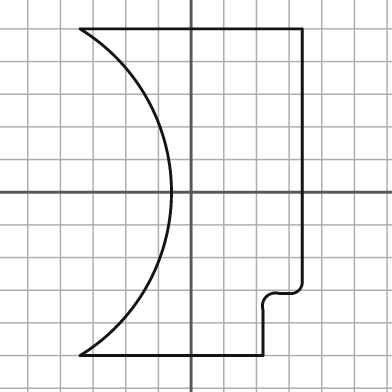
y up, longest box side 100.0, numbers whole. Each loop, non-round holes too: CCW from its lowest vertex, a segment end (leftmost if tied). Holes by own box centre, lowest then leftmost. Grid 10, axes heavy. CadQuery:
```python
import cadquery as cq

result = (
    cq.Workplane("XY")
    .moveTo(-34.0, -50.0)
    .lineTo(22.0, -50.0)
    .lineTo(22.0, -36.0)
    .threePointArc((23.0, -32.0), (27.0, -31.0))
    .lineTo(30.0, -31.0)
    .threePointArc((33.0, -30.0), (34.0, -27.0))
    .lineTo(34.0, 50.0)
    .lineTo(-34.0, 50.0)
    .threePointArc((-6.0, 0.0), (-34.0, -50.0))
    .close()
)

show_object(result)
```